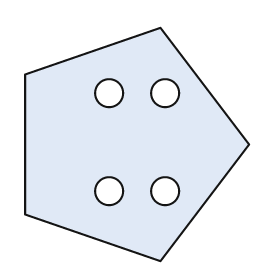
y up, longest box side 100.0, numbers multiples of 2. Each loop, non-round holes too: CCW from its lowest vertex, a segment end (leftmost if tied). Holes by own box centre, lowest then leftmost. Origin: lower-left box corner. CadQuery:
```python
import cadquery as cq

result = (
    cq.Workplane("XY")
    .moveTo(58.0, 0.0)
    .lineTo(96.0, 50.0)
    .lineTo(58.0, 100.0)
    .lineTo(0.0, 80.0)
    .lineTo(0.0, 20.0)
    .close()
    .moveTo(36.0, 30.0)
    .circle(6.0)
    .moveTo(60.0, 30.0)
    .circle(6.0)
    .moveTo(36.0, 72.0)
    .circle(6.0)
    .moveTo(60.0, 72.0)
    .circle(6.0)
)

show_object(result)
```